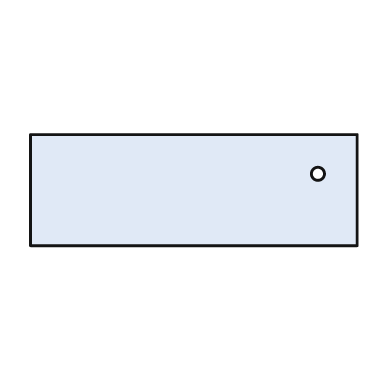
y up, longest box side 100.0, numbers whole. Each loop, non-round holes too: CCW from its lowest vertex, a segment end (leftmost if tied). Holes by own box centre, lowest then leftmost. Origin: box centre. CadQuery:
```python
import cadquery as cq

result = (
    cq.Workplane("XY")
    .moveTo(-50.0, -17.0)
    .lineTo(50.0, -17.0)
    .lineTo(50.0, 17.0)
    .lineTo(-50.0, 17.0)
    .close()
    .moveTo(38.0, 5.0)
    .circle(2.0)
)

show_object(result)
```